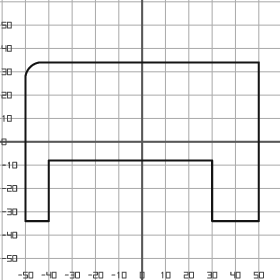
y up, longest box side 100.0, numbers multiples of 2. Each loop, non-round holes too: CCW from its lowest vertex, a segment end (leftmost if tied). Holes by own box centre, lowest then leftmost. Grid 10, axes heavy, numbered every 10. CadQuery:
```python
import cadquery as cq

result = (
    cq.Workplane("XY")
    .moveTo(-50.0, -34.0)
    .lineTo(-40.0, -34.0)
    .lineTo(-40.0, -8.0)
    .lineTo(30.0, -8.0)
    .lineTo(30.0, -34.0)
    .lineTo(50.0, -34.0)
    .lineTo(50.0, 34.0)
    .lineTo(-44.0, 34.0)
    .threePointArc((-48.0, 32.0), (-50.0, 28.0))
    .close()
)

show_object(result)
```